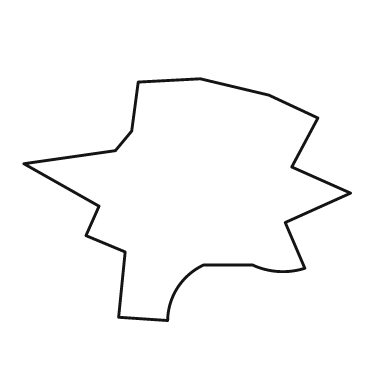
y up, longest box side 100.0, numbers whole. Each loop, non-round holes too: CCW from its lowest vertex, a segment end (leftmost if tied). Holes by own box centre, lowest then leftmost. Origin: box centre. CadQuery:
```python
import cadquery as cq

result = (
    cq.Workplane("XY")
    .moveTo(-6.0, -37.0)
    .threePointArc((-3.0, -27.0), (5.0, -20.0))
    .lineTo(20.0, -20.0)
    .threePointArc((28.0, -22.0), (36.0, -21.0))
    .lineTo(30.0, -7.0)
    .lineTo(50.0, 2.0)
    .lineTo(32.0, 10.0)
    .lineTo(40.0, 25.0)
    .lineTo(25.0, 32.0)
    .lineTo(4.0, 37.0)
    .lineTo(-15.0, 36.0)
    .lineTo(-17.0, 21.0)
    .lineTo(-22.0, 15.0)
    .lineTo(-50.0, 11.0)
    .lineTo(-27.0, -2.0)
    .lineTo(-31.0, -11.0)
    .lineTo(-19.0, -16.0)
    .lineTo(-21.0, -36.0)
    .close()
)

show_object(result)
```